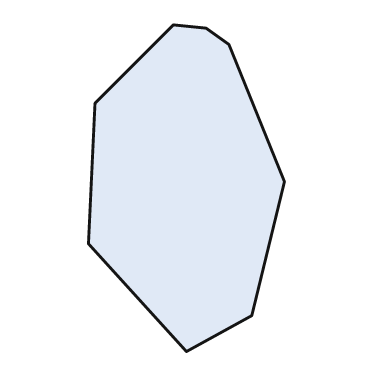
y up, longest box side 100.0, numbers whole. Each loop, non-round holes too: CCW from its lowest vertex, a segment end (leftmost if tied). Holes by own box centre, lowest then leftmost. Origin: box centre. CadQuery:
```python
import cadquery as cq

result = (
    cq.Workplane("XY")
    .moveTo(0.0, -50.0)
    .lineTo(20.0, -39.0)
    .lineTo(30.0, 2.0)
    .lineTo(13.0, 44.0)
    .lineTo(6.0, 49.0)
    .lineTo(-4.0, 50.0)
    .lineTo(-28.0, 26.0)
    .lineTo(-30.0, -17.0)
    .close()
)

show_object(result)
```